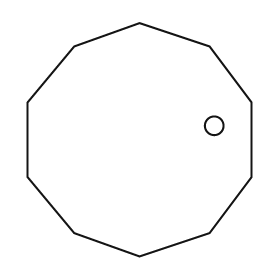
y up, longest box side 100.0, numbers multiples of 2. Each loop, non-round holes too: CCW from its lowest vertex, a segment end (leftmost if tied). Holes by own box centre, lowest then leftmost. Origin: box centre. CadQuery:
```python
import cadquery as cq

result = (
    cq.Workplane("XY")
    .moveTo(0.0, -50.0)
    .lineTo(30.0, -40.0)
    .lineTo(48.0, -16.0)
    .lineTo(48.0, 16.0)
    .lineTo(30.0, 40.0)
    .lineTo(0.0, 50.0)
    .lineTo(-28.0, 40.0)
    .lineTo(-48.0, 16.0)
    .lineTo(-48.0, -16.0)
    .lineTo(-28.0, -40.0)
    .close()
    .moveTo(32.0, 6.0)
    .circle(4.0)
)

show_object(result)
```